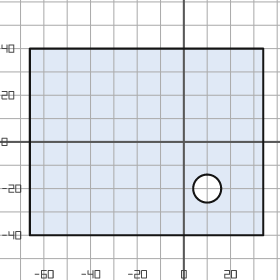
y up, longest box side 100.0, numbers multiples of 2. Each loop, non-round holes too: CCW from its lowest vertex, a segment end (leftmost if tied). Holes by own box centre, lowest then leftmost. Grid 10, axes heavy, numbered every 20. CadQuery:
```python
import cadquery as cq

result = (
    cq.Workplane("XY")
    .moveTo(-66.0, -40.0)
    .lineTo(34.0, -40.0)
    .lineTo(34.0, 40.0)
    .lineTo(-66.0, 40.0)
    .close()
    .moveTo(10.0, -20.0)
    .circle(6.0)
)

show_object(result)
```